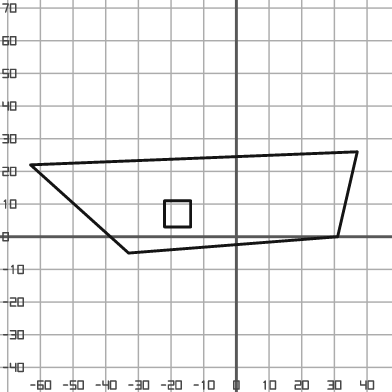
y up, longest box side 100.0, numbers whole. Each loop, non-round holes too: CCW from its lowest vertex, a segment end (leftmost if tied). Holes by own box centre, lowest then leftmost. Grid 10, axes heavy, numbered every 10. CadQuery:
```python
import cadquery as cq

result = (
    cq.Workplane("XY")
    .moveTo(-33.0, -5.0)
    .lineTo(31.0, 0.0)
    .lineTo(37.0, 26.0)
    .lineTo(-63.0, 22.0)
    .close()
    .moveTo(-22.0, 3.0)
    .lineTo(-14.0, 3.0)
    .lineTo(-14.0, 11.0)
    .lineTo(-22.0, 11.0)
    .close()
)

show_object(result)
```